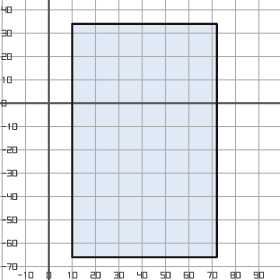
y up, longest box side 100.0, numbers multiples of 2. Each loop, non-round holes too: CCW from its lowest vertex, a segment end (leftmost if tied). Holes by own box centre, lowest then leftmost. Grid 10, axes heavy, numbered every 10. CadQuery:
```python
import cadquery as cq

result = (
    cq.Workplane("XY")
    .moveTo(10.0, -66.0)
    .lineTo(72.0, -66.0)
    .lineTo(72.0, 34.0)
    .lineTo(10.0, 34.0)
    .close()
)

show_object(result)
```